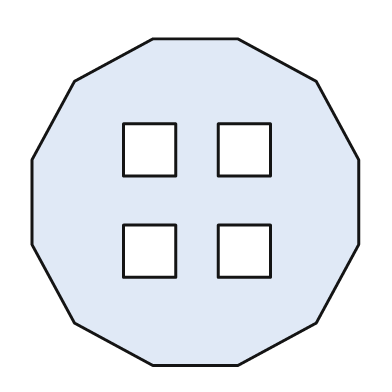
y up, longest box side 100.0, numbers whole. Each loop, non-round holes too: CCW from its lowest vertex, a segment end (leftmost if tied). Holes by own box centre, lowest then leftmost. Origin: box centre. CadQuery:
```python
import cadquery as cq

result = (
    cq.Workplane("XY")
    .moveTo(-13.0, -50.0)
    .lineTo(13.0, -50.0)
    .lineTo(37.0, -37.0)
    .lineTo(50.0, -13.0)
    .lineTo(50.0, 13.0)
    .lineTo(37.0, 37.0)
    .lineTo(13.0, 50.0)
    .lineTo(-13.0, 50.0)
    .lineTo(-37.0, 37.0)
    .lineTo(-50.0, 13.0)
    .lineTo(-50.0, -13.0)
    .lineTo(-37.0, -37.0)
    .close()
    .moveTo(-22.0, -23.0)
    .lineTo(-6.0, -23.0)
    .lineTo(-6.0, -7.0)
    .lineTo(-22.0, -7.0)
    .close()
    .moveTo(7.0, -23.0)
    .lineTo(23.0, -23.0)
    .lineTo(23.0, -7.0)
    .lineTo(7.0, -7.0)
    .close()
    .moveTo(-22.0, 8.0)
    .lineTo(-6.0, 8.0)
    .lineTo(-6.0, 24.0)
    .lineTo(-22.0, 24.0)
    .close()
    .moveTo(7.0, 8.0)
    .lineTo(23.0, 8.0)
    .lineTo(23.0, 24.0)
    .lineTo(7.0, 24.0)
    .close()
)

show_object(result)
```